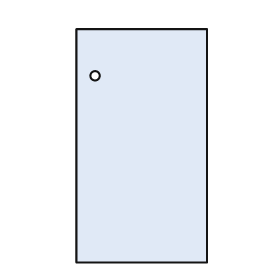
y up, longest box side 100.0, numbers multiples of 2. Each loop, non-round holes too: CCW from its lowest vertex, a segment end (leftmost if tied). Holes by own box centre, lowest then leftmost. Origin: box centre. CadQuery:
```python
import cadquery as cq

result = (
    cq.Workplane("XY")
    .moveTo(-28.0, -50.0)
    .lineTo(28.0, -50.0)
    .lineTo(28.0, 50.0)
    .lineTo(-28.0, 50.0)
    .close()
    .moveTo(-20.0, 30.0)
    .circle(2.0)
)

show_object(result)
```